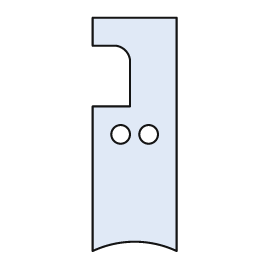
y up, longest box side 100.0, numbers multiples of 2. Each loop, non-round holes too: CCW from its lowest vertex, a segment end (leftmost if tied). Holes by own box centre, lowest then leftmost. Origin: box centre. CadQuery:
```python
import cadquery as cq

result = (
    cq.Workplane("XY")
    .moveTo(-18.0, -50.0)
    .threePointArc((0.0, -46.0), (18.0, -50.0))
    .lineTo(18.0, 50.0)
    .lineTo(-18.0, 50.0)
    .lineTo(-18.0, 38.0)
    .lineTo(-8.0, 38.0)
    .threePointArc((-4.0, 36.0), (-2.0, 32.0))
    .lineTo(-2.0, 12.0)
    .lineTo(-18.0, 12.0)
    .close()
    .moveTo(-6.0, 0.0)
    .circle(4.0)
    .moveTo(6.0, 0.0)
    .circle(4.0)
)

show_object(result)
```